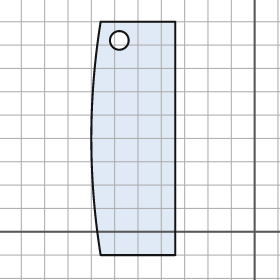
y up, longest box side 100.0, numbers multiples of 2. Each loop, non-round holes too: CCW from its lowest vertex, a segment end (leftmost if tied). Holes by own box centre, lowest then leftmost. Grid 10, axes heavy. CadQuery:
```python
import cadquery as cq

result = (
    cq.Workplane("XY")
    .moveTo(-66.0, -10.0)
    .lineTo(-34.0, -10.0)
    .lineTo(-34.0, 90.0)
    .lineTo(-66.0, 90.0)
    .threePointArc((-70.0, 40.0), (-66.0, -10.0))
    .close()
    .moveTo(-58.0, 82.0)
    .circle(4.0)
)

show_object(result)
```